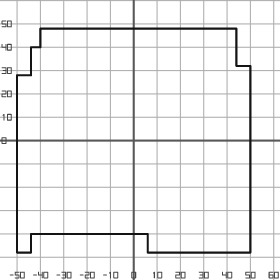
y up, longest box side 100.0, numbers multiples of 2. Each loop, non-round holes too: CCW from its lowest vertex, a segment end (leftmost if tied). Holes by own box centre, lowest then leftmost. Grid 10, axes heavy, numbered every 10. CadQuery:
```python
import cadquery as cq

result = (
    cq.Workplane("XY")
    .moveTo(-50.0, -48.0)
    .lineTo(-44.0, -48.0)
    .lineTo(-44.0, -40.0)
    .lineTo(6.0, -40.0)
    .lineTo(6.0, -48.0)
    .lineTo(50.0, -48.0)
    .lineTo(50.0, 32.0)
    .lineTo(44.0, 32.0)
    .lineTo(44.0, 48.0)
    .lineTo(-40.0, 48.0)
    .lineTo(-40.0, 40.0)
    .lineTo(-44.0, 40.0)
    .lineTo(-44.0, 28.0)
    .lineTo(-50.0, 28.0)
    .close()
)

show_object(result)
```